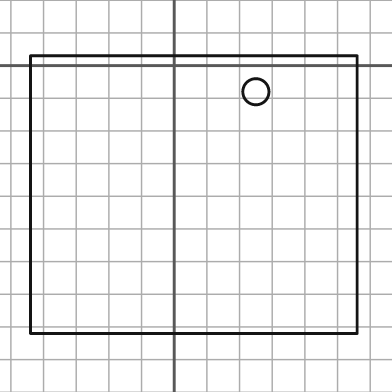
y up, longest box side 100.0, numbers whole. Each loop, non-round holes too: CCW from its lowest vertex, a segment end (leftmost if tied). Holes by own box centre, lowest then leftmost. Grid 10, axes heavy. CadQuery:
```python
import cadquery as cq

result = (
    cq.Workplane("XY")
    .moveTo(-44.0, -82.0)
    .lineTo(56.0, -82.0)
    .lineTo(56.0, 3.0)
    .lineTo(-44.0, 3.0)
    .close()
    .moveTo(25.0, -8.0)
    .circle(4.0)
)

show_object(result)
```